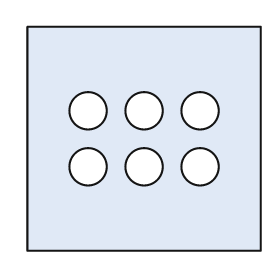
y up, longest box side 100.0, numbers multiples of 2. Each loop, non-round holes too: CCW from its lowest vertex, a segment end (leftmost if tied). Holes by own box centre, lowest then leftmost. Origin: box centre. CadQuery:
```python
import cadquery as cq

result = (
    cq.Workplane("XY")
    .moveTo(-50.0, -48.0)
    .lineTo(50.0, -48.0)
    .lineTo(50.0, 48.0)
    .lineTo(-50.0, 48.0)
    .close()
    .moveTo(-24.0, -12.0)
    .circle(8.0)
    .moveTo(0.0, -12.0)
    .circle(8.0)
    .moveTo(24.0, -12.0)
    .circle(8.0)
    .moveTo(-24.0, 12.0)
    .circle(8.0)
    .moveTo(0.0, 12.0)
    .circle(8.0)
    .moveTo(24.0, 12.0)
    .circle(8.0)
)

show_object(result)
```